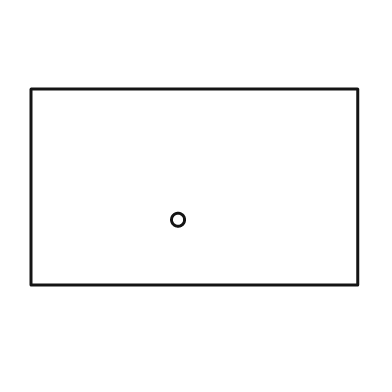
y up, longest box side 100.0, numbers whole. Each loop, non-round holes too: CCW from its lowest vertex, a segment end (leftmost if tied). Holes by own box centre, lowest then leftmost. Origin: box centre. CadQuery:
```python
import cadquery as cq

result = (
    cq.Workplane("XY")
    .moveTo(-50.0, -30.0)
    .lineTo(50.0, -30.0)
    .lineTo(50.0, 30.0)
    .lineTo(-50.0, 30.0)
    .close()
    .moveTo(-5.0, -10.0)
    .circle(2.0)
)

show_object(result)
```